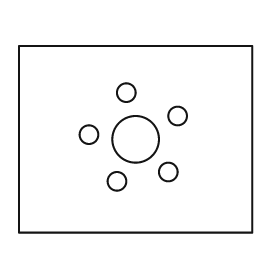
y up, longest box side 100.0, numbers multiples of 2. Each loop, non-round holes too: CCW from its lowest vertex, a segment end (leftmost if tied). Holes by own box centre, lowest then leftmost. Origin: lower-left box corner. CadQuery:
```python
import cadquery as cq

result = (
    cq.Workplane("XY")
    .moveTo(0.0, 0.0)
    .lineTo(100.0, 0.0)
    .lineTo(100.0, 80.0)
    .lineTo(0.0, 80.0)
    .close()
    .moveTo(42.0, 22.0)
    .circle(4.0)
    .moveTo(64.0, 26.0)
    .circle(4.0)
    .moveTo(50.0, 40.0)
    .circle(10.0)
    .moveTo(30.0, 42.0)
    .circle(4.0)
    .moveTo(68.0, 50.0)
    .circle(4.0)
    .moveTo(46.0, 60.0)
    .circle(4.0)
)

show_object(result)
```